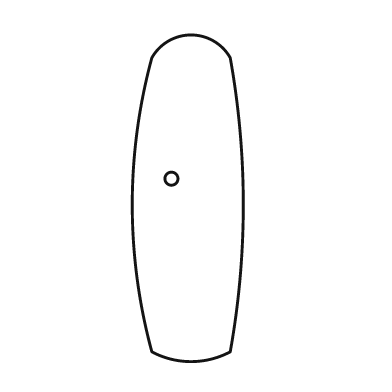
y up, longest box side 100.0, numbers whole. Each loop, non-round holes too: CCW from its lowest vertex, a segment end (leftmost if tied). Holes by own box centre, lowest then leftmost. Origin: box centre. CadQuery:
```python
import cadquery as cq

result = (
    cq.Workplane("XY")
    .moveTo(-11.0, -47.0)
    .threePointArc((1.0, -50.0), (13.0, -47.0))
    .threePointArc((17.0, -2.0), (13.0, 43.0))
    .threePointArc((1.0, 50.0), (-11.0, 43.0))
    .threePointArc((-17.0, -2.0), (-11.0, -47.0))
    .close()
    .moveTo(-5.0, 6.0)
    .circle(2.0)
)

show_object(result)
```